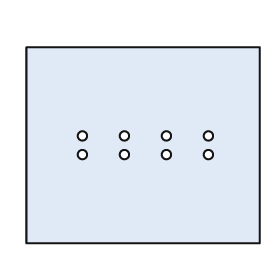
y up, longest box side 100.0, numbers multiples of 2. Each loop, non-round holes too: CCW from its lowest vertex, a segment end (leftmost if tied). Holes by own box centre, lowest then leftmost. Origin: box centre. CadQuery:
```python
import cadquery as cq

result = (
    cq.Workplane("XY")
    .moveTo(-50.0, -42.0)
    .lineTo(50.0, -42.0)
    .lineTo(50.0, 42.0)
    .lineTo(-50.0, 42.0)
    .close()
    .moveTo(-26.0, -4.0)
    .circle(2.0)
    .moveTo(-8.0, -4.0)
    .circle(2.0)
    .moveTo(10.0, -4.0)
    .circle(2.0)
    .moveTo(28.0, -4.0)
    .circle(2.0)
    .moveTo(-26.0, 4.0)
    .circle(2.0)
    .moveTo(-8.0, 4.0)
    .circle(2.0)
    .moveTo(10.0, 4.0)
    .circle(2.0)
    .moveTo(28.0, 4.0)
    .circle(2.0)
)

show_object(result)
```